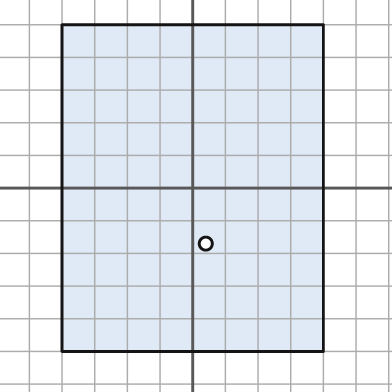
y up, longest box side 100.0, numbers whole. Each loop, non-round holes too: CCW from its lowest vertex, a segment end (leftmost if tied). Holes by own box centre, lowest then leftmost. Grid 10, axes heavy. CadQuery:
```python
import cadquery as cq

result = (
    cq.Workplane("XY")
    .moveTo(-40.0, -50.0)
    .lineTo(40.0, -50.0)
    .lineTo(40.0, 50.0)
    .lineTo(-40.0, 50.0)
    .close()
    .moveTo(4.0, -17.0)
    .circle(2.0)
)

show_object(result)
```